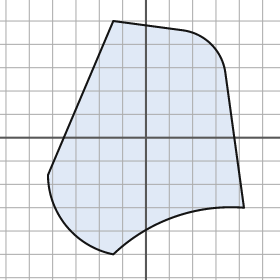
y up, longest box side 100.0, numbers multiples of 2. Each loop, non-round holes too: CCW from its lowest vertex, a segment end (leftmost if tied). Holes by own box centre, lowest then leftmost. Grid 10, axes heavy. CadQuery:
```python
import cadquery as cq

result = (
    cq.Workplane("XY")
    .moveTo(-14.0, -50.0)
    .threePointArc((12.0, -34.0), (42.0, -30.0))
    .lineTo(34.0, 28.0)
    .threePointArc((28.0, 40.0), (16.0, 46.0))
    .lineTo(-14.0, 50.0)
    .lineTo(-42.0, -16.0)
    .threePointArc((-34.0, -38.0), (-14.0, -50.0))
    .close()
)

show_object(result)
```